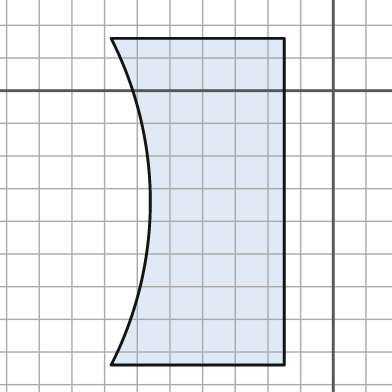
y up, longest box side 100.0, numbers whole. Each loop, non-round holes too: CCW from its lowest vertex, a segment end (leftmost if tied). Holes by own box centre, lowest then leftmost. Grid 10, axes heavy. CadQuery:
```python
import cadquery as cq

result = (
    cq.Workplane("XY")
    .moveTo(-68.0, -84.0)
    .lineTo(-15.0, -84.0)
    .lineTo(-15.0, 16.0)
    .lineTo(-68.0, 16.0)
    .threePointArc((-56.0, -34.0), (-68.0, -84.0))
    .close()
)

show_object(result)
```